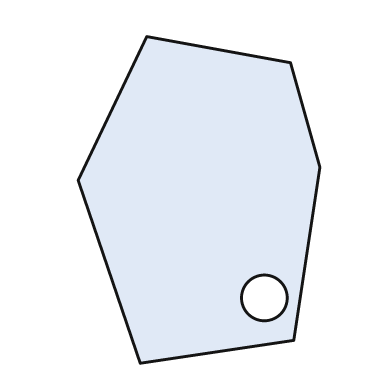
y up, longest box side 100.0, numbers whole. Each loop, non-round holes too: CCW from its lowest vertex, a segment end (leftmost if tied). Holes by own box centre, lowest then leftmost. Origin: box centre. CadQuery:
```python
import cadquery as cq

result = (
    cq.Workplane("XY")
    .moveTo(-18.0, -50.0)
    .lineTo(29.0, -43.0)
    .lineTo(37.0, 10.0)
    .lineTo(28.0, 42.0)
    .lineTo(-16.0, 50.0)
    .lineTo(-37.0, 6.0)
    .close()
    .moveTo(20.0, -30.0)
    .circle(7.0)
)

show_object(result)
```